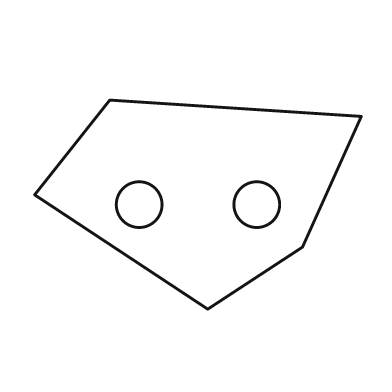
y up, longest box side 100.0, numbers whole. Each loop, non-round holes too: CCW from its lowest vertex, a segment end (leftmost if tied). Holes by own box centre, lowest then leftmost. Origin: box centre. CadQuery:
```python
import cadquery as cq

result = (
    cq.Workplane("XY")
    .moveTo(3.0, -32.0)
    .lineTo(32.0, -13.0)
    .lineTo(50.0, 27.0)
    .lineTo(-27.0, 32.0)
    .lineTo(-50.0, 3.0)
    .close()
    .moveTo(-18.0, 0.0)
    .circle(7.0)
    .moveTo(18.0, 0.0)
    .circle(7.0)
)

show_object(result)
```